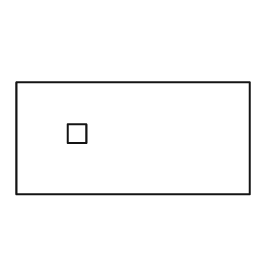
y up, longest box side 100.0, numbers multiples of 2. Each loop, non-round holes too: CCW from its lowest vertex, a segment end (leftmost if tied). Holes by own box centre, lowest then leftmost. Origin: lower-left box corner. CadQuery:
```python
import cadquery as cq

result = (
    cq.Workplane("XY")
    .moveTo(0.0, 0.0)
    .lineTo(100.0, 0.0)
    .lineTo(100.0, 48.0)
    .lineTo(0.0, 48.0)
    .close()
    .moveTo(22.0, 22.0)
    .lineTo(30.0, 22.0)
    .lineTo(30.0, 30.0)
    .lineTo(22.0, 30.0)
    .close()
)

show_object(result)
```